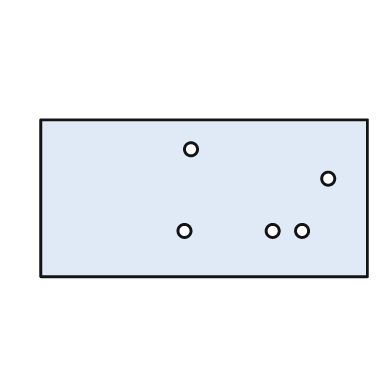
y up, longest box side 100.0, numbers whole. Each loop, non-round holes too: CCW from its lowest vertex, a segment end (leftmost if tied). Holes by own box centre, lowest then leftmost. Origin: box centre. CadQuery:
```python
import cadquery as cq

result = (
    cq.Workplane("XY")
    .moveTo(-50.0, -24.0)
    .lineTo(50.0, -24.0)
    .lineTo(50.0, 24.0)
    .lineTo(-50.0, 24.0)
    .close()
    .moveTo(-6.0, -10.0)
    .circle(2.0)
    .moveTo(21.0, -10.0)
    .circle(2.0)
    .moveTo(30.0, -10.0)
    .circle(2.0)
    .moveTo(38.0, 6.0)
    .circle(2.0)
    .moveTo(-4.0, 15.0)
    .circle(2.0)
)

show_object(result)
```